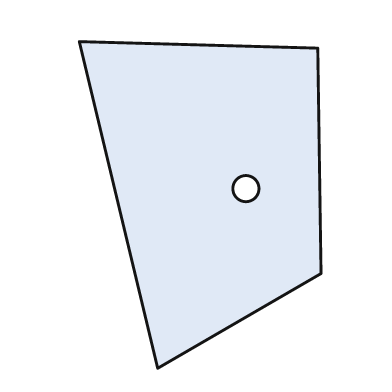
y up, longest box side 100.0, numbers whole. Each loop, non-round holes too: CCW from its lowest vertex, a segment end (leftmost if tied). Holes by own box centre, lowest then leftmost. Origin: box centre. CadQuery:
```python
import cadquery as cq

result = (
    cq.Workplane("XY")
    .moveTo(-13.0, -50.0)
    .lineTo(37.0, -21.0)
    .lineTo(36.0, 48.0)
    .lineTo(-37.0, 50.0)
    .close()
    .moveTo(14.0, 5.0)
    .circle(4.0)
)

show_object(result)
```